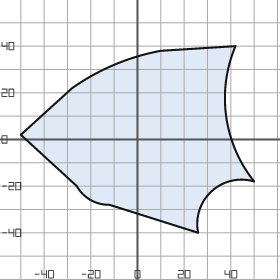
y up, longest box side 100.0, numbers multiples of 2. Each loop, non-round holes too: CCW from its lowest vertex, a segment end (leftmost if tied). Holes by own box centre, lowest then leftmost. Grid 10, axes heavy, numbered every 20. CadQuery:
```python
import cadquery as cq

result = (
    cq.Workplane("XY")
    .moveTo(26.0, -40.0)
    .threePointArc((32.0, -22.0), (50.0, -18.0))
    .threePointArc((38.0, 10.0), (42.0, 40.0))
    .lineTo(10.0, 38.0)
    .threePointArc((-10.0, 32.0), (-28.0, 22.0))
    .lineTo(-50.0, 2.0)
    .lineTo(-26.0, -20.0)
    .threePointArc((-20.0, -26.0), (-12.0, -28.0))
    .close()
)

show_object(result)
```